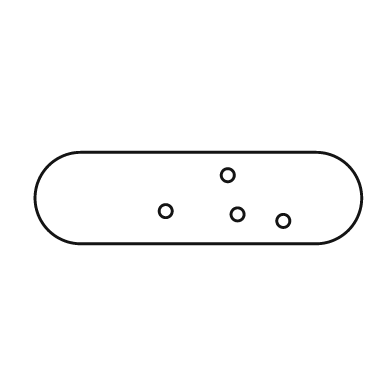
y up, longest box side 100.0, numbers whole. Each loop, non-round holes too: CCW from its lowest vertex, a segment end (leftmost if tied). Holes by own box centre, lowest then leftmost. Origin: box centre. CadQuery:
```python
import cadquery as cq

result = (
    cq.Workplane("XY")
    .moveTo(-36.0, -14.0)
    .lineTo(36.0, -14.0)
    .threePointArc((50.0, 0.0), (36.0, 14.0))
    .lineTo(-36.0, 14.0)
    .threePointArc((-50.0, 0.0), (-36.0, -14.0))
    .close()
    .moveTo(26.0, -7.0)
    .circle(2.0)
    .moveTo(12.0, -5.0)
    .circle(2.0)
    .moveTo(-10.0, -4.0)
    .circle(2.0)
    .moveTo(9.0, 7.0)
    .circle(2.0)
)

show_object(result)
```